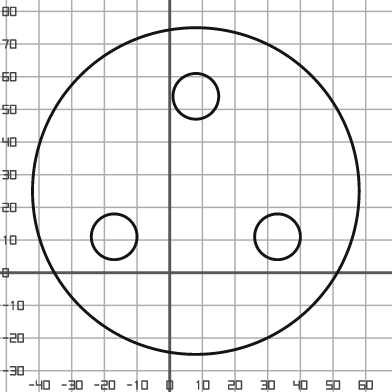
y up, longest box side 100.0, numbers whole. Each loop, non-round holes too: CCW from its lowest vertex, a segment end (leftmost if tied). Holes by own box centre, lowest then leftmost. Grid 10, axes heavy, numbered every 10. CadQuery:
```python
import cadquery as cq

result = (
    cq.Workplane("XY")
    .moveTo(8.0, 25.0)
    .circle(50.0)
    .moveTo(-17.0, 11.0)
    .circle(7.0)
    .moveTo(33.0, 11.0)
    .circle(7.0)
    .moveTo(8.0, 54.0)
    .circle(7.0)
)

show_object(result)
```